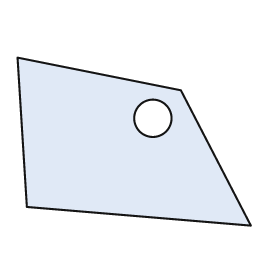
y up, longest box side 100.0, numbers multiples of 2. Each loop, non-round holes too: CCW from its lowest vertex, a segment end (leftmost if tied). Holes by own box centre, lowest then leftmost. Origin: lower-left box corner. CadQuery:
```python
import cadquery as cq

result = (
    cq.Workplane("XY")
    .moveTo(100.0, 0.0)
    .lineTo(70.0, 58.0)
    .lineTo(0.0, 72.0)
    .lineTo(4.0, 8.0)
    .close()
    .moveTo(58.0, 46.0)
    .circle(8.0)
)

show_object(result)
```